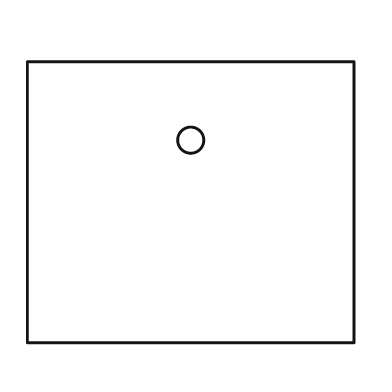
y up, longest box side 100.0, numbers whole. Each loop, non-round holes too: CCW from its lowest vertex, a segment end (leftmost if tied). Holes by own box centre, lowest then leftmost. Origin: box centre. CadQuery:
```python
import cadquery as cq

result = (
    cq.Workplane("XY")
    .moveTo(-50.0, -43.0)
    .lineTo(50.0, -43.0)
    .lineTo(50.0, 43.0)
    .lineTo(-50.0, 43.0)
    .close()
    .moveTo(0.0, 19.0)
    .circle(4.0)
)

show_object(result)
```